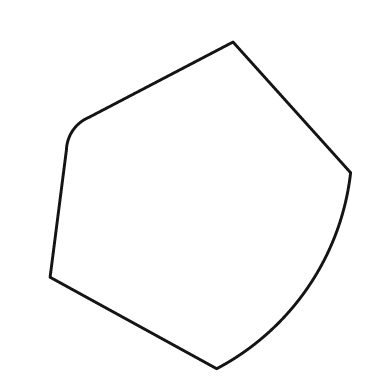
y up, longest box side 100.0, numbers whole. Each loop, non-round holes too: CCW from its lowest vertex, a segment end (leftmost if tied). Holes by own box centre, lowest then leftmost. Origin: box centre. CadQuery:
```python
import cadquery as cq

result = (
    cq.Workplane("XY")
    .moveTo(5.0, -50.0)
    .threePointArc((33.0, -25.0), (46.0, 10.0))
    .lineTo(10.0, 50.0)
    .lineTo(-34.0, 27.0)
    .threePointArc((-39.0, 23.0), (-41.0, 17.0))
    .lineTo(-46.0, -22.0)
    .close()
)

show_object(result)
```